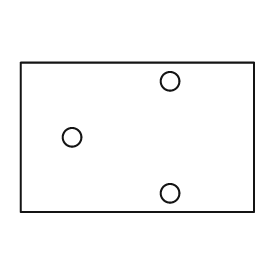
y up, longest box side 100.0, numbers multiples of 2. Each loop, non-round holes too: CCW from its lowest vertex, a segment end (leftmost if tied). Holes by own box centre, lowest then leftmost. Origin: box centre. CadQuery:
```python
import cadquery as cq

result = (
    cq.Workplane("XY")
    .moveTo(-50.0, -32.0)
    .lineTo(50.0, -32.0)
    .lineTo(50.0, 32.0)
    .lineTo(-50.0, 32.0)
    .close()
    .moveTo(14.0, -24.0)
    .circle(4.0)
    .moveTo(-28.0, 0.0)
    .circle(4.0)
    .moveTo(14.0, 24.0)
    .circle(4.0)
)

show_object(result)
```